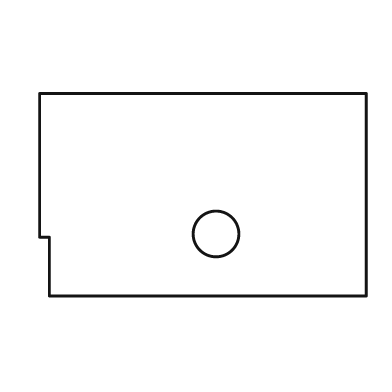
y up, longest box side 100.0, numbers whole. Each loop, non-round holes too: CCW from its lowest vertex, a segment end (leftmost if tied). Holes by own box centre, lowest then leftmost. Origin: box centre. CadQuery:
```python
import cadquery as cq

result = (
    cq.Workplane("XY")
    .moveTo(-47.0, -31.0)
    .lineTo(50.0, -31.0)
    .lineTo(50.0, 31.0)
    .lineTo(-50.0, 31.0)
    .lineTo(-50.0, -13.0)
    .lineTo(-47.0, -13.0)
    .close()
    .moveTo(4.0, -12.0)
    .circle(7.0)
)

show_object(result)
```